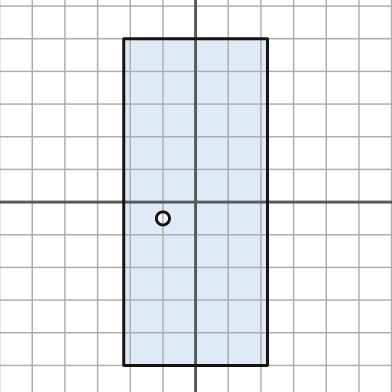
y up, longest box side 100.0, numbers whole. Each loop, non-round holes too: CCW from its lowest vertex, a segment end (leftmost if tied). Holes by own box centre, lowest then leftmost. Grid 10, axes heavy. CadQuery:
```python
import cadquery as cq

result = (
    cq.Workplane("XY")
    .moveTo(-22.0, -50.0)
    .lineTo(22.0, -50.0)
    .lineTo(22.0, 50.0)
    .lineTo(-22.0, 50.0)
    .close()
    .moveTo(-10.0, -5.0)
    .circle(2.0)
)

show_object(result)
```